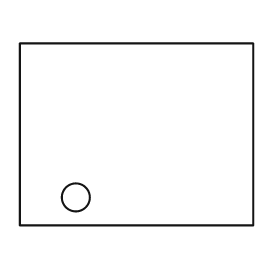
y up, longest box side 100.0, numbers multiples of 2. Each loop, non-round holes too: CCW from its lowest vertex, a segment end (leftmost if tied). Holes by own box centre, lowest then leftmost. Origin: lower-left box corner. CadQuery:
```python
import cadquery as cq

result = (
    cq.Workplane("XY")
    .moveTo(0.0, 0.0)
    .lineTo(100.0, 0.0)
    .lineTo(100.0, 78.0)
    .lineTo(0.0, 78.0)
    .close()
    .moveTo(24.0, 12.0)
    .circle(6.0)
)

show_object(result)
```